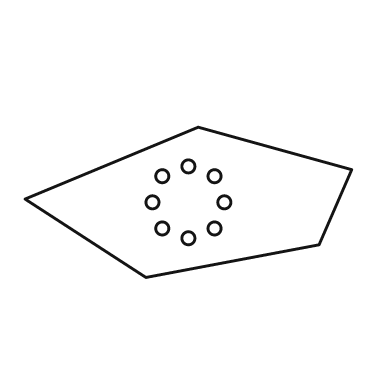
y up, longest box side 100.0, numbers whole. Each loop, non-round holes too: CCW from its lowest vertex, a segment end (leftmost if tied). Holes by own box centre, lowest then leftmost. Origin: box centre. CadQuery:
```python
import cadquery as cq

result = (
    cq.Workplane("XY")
    .moveTo(-13.0, -23.0)
    .lineTo(40.0, -13.0)
    .lineTo(50.0, 10.0)
    .lineTo(3.0, 23.0)
    .lineTo(-50.0, 1.0)
    .close()
    .moveTo(0.0, -11.0)
    .circle(2.0)
    .moveTo(-8.0, -8.0)
    .circle(2.0)
    .moveTo(8.0, -8.0)
    .circle(2.0)
    .moveTo(-11.0, 0.0)
    .circle(2.0)
    .moveTo(11.0, 0.0)
    .circle(2.0)
    .moveTo(-8.0, 8.0)
    .circle(2.0)
    .moveTo(8.0, 8.0)
    .circle(2.0)
    .moveTo(0.0, 11.0)
    .circle(2.0)
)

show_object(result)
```